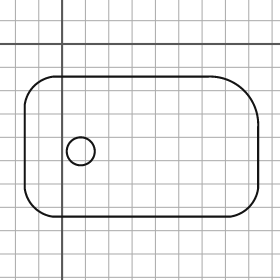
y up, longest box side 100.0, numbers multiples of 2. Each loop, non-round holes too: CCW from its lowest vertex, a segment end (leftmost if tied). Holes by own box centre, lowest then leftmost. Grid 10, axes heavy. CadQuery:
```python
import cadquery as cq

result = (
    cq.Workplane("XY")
    .moveTo(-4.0, -74.0)
    .lineTo(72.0, -74.0)
    .threePointArc((80.0, -70.0), (84.0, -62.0))
    .lineTo(84.0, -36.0)
    .threePointArc((78.0, -20.0), (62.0, -14.0))
    .lineTo(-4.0, -14.0)
    .threePointArc((-12.0, -18.0), (-16.0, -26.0))
    .lineTo(-16.0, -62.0)
    .threePointArc((-12.0, -70.0), (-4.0, -74.0))
    .close()
    .moveTo(8.0, -46.0)
    .circle(6.0)
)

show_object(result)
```